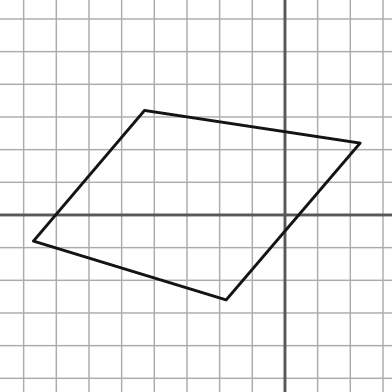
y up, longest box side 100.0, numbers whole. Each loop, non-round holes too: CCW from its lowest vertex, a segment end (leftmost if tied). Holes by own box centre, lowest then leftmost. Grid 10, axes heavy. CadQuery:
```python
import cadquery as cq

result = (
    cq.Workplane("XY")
    .moveTo(-18.0, -26.0)
    .lineTo(23.0, 22.0)
    .lineTo(-43.0, 32.0)
    .lineTo(-77.0, -8.0)
    .close()
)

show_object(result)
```